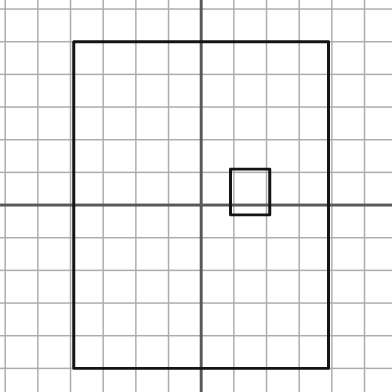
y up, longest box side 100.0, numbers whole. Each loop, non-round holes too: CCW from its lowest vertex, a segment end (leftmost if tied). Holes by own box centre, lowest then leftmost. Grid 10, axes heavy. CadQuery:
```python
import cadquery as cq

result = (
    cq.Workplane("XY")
    .moveTo(-39.0, -50.0)
    .lineTo(39.0, -50.0)
    .lineTo(39.0, 50.0)
    .lineTo(-39.0, 50.0)
    .close()
    .moveTo(9.0, -3.0)
    .lineTo(21.0, -3.0)
    .lineTo(21.0, 11.0)
    .lineTo(9.0, 11.0)
    .close()
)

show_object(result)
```